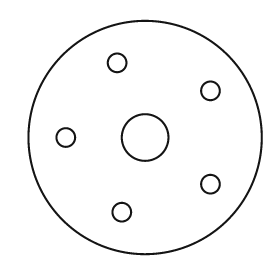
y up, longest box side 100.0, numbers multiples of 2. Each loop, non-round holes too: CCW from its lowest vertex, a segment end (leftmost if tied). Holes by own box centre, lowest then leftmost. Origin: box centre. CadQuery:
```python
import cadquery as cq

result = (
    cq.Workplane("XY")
    .moveTo(0.0, 0.0)
    .circle(50.0)
    .moveTo(-10.0, -32.0)
    .circle(4.0)
    .moveTo(28.0, -20.0)
    .circle(4.0)
    .moveTo(-34.0, 0.0)
    .circle(4.0)
    .moveTo(0.0, 0.0)
    .circle(10.0)
    .moveTo(28.0, 20.0)
    .circle(4.0)
    .moveTo(-12.0, 32.0)
    .circle(4.0)
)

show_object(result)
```